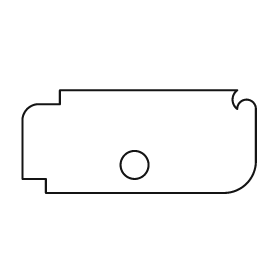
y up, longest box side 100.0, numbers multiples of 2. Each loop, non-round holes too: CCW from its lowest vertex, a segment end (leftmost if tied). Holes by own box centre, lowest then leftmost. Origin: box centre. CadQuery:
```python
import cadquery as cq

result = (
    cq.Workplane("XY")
    .moveTo(-40.0, -22.0)
    .lineTo(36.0, -22.0)
    .threePointArc((46.0, -18.0), (50.0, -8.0))
    .lineTo(50.0, 14.0)
    .threePointArc((46.0, 18.0), (42.0, 14.0))
    .threePointArc((40.0, 18.0), (42.0, 22.0))
    .lineTo(-34.0, 22.0)
    .lineTo(-34.0, 16.0)
    .lineTo(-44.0, 16.0)
    .threePointArc((-48.0, 14.0), (-50.0, 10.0))
    .lineTo(-50.0, -16.0)
    .lineTo(-40.0, -16.0)
    .close()
    .moveTo(-2.0, -10.0)
    .circle(6.0)
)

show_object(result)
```